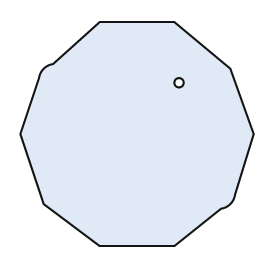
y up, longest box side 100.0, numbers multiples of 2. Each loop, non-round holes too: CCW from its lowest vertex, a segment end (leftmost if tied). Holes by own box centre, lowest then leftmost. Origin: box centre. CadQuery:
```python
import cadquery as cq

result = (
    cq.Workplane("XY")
    .moveTo(-16.0, -48.0)
    .lineTo(16.0, -48.0)
    .lineTo(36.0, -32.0)
    .threePointArc((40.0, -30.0), (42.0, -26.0))
    .lineTo(50.0, 0.0)
    .lineTo(40.0, 28.0)
    .lineTo(16.0, 48.0)
    .lineTo(-16.0, 48.0)
    .lineTo(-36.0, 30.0)
    .threePointArc((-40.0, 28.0), (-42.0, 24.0))
    .lineTo(-50.0, 0.0)
    .lineTo(-40.0, -30.0)
    .close()
    .moveTo(18.0, 22.0)
    .circle(2.0)
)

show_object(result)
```